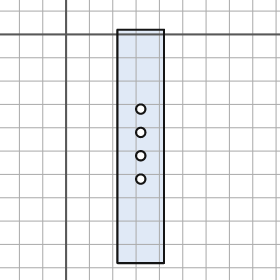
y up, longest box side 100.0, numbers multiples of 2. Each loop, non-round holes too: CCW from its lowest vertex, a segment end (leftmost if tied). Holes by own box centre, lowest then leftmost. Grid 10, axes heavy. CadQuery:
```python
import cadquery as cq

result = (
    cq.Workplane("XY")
    .moveTo(22.0, -98.0)
    .lineTo(42.0, -98.0)
    .lineTo(42.0, 2.0)
    .lineTo(22.0, 2.0)
    .close()
    .moveTo(32.0, -62.0)
    .circle(2.0)
    .moveTo(32.0, -52.0)
    .circle(2.0)
    .moveTo(32.0, -42.0)
    .circle(2.0)
    .moveTo(32.0, -32.0)
    .circle(2.0)
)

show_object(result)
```